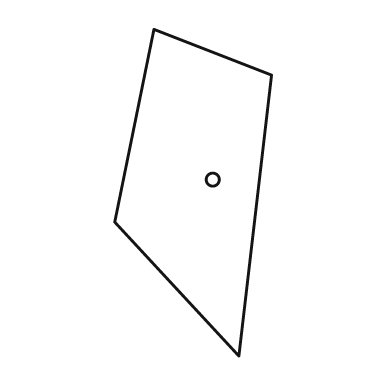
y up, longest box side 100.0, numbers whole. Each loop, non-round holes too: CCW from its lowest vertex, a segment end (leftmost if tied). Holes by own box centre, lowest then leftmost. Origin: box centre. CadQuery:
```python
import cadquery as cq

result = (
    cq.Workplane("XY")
    .moveTo(14.0, -50.0)
    .lineTo(24.0, 36.0)
    .lineTo(-12.0, 50.0)
    .lineTo(-24.0, -9.0)
    .close()
    .moveTo(6.0, 4.0)
    .circle(2.0)
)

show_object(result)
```